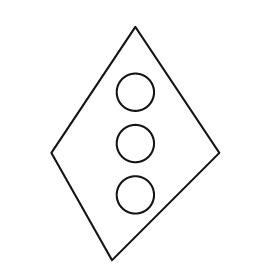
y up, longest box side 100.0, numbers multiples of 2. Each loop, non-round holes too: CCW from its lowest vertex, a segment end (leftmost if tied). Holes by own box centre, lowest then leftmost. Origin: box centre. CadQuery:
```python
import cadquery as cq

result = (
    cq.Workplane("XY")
    .moveTo(-10.0, -50.0)
    .lineTo(36.0, -4.0)
    .lineTo(0.0, 50.0)
    .lineTo(-36.0, -4.0)
    .close()
    .moveTo(0.0, -22.0)
    .circle(8.0)
    .moveTo(0.0, 0.0)
    .circle(8.0)
    .moveTo(0.0, 22.0)
    .circle(8.0)
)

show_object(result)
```